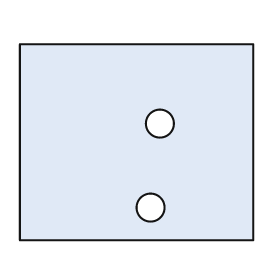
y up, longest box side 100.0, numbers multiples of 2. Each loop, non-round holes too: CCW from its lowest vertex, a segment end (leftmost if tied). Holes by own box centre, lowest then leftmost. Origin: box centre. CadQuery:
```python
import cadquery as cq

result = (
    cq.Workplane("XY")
    .moveTo(-50.0, -42.0)
    .lineTo(50.0, -42.0)
    .lineTo(50.0, 42.0)
    .lineTo(-50.0, 42.0)
    .close()
    .moveTo(6.0, -28.0)
    .circle(6.0)
    .moveTo(10.0, 8.0)
    .circle(6.0)
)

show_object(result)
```